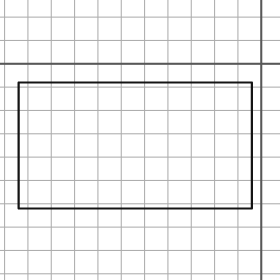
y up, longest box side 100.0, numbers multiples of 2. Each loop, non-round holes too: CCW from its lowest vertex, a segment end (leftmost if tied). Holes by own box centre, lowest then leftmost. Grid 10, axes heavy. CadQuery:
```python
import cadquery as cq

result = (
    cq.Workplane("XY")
    .moveTo(-104.0, -62.0)
    .lineTo(-4.0, -62.0)
    .lineTo(-4.0, -8.0)
    .lineTo(-104.0, -8.0)
    .close()
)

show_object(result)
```